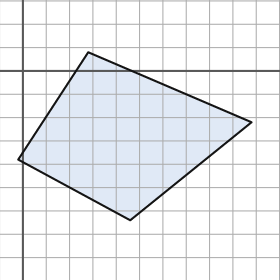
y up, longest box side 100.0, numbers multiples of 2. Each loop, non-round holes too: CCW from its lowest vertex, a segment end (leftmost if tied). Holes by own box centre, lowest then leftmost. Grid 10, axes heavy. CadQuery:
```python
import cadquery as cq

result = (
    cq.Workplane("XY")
    .moveTo(46.0, -64.0)
    .lineTo(98.0, -22.0)
    .lineTo(28.0, 8.0)
    .lineTo(-2.0, -38.0)
    .close()
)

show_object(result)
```